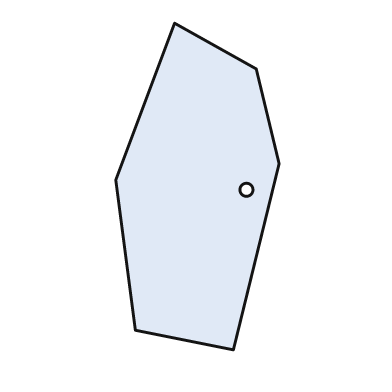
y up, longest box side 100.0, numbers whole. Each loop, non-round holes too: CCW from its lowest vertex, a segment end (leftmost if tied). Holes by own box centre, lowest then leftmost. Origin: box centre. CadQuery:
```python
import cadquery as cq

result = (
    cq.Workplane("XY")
    .moveTo(11.0, -50.0)
    .lineTo(25.0, 7.0)
    .lineTo(18.0, 36.0)
    .lineTo(-7.0, 50.0)
    .lineTo(-25.0, 2.0)
    .lineTo(-19.0, -44.0)
    .close()
    .moveTo(15.0, -1.0)
    .circle(2.0)
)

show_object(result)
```